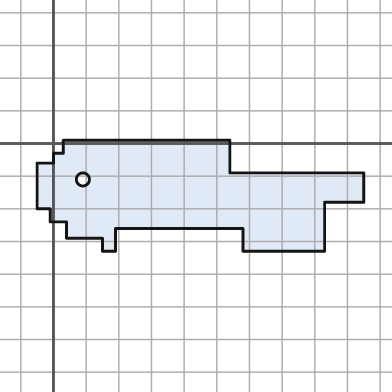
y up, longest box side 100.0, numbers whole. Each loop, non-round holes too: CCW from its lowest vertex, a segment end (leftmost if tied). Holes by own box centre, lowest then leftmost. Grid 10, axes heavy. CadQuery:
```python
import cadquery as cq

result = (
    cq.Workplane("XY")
    .moveTo(15.0, -33.0)
    .lineTo(19.0, -33.0)
    .lineTo(19.0, -26.0)
    .lineTo(58.0, -26.0)
    .lineTo(58.0, -33.0)
    .lineTo(83.0, -33.0)
    .lineTo(83.0, -18.0)
    .lineTo(95.0, -18.0)
    .lineTo(95.0, -9.0)
    .lineTo(54.0, -9.0)
    .lineTo(54.0, 1.0)
    .lineTo(3.0, 1.0)
    .lineTo(3.0, -3.0)
    .lineTo(0.0, -3.0)
    .lineTo(0.0, -6.0)
    .lineTo(-5.0, -6.0)
    .lineTo(-5.0, -20.0)
    .lineTo(-1.0, -20.0)
    .lineTo(-1.0, -24.0)
    .lineTo(4.0, -24.0)
    .lineTo(4.0, -29.0)
    .lineTo(15.0, -29.0)
    .close()
    .moveTo(9.0, -11.0)
    .circle(2.0)
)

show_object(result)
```